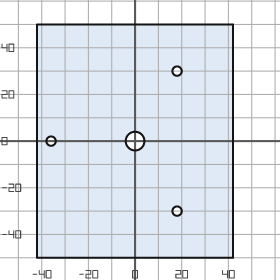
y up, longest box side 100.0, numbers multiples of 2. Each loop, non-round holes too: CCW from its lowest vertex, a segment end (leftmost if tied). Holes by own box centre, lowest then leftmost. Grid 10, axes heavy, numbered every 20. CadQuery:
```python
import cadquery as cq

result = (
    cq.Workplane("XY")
    .moveTo(-42.0, -50.0)
    .lineTo(42.0, -50.0)
    .lineTo(42.0, 50.0)
    .lineTo(-42.0, 50.0)
    .close()
    .moveTo(18.0, -30.0)
    .circle(2.0)
    .moveTo(-36.0, 0.0)
    .circle(2.0)
    .moveTo(0.0, 0.0)
    .circle(4.0)
    .moveTo(18.0, 30.0)
    .circle(2.0)
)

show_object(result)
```